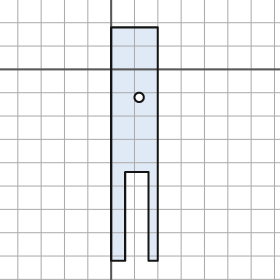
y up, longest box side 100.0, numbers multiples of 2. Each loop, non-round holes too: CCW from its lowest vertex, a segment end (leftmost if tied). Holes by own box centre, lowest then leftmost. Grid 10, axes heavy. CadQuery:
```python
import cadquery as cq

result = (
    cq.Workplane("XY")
    .moveTo(0.0, -82.0)
    .lineTo(6.0, -82.0)
    .lineTo(6.0, -44.0)
    .lineTo(16.0, -44.0)
    .lineTo(16.0, -82.0)
    .lineTo(20.0, -82.0)
    .lineTo(20.0, 18.0)
    .lineTo(0.0, 18.0)
    .close()
    .moveTo(12.0, -12.0)
    .circle(2.0)
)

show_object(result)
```